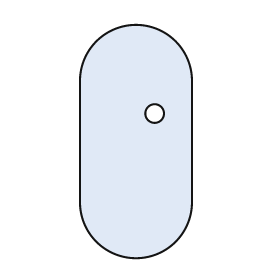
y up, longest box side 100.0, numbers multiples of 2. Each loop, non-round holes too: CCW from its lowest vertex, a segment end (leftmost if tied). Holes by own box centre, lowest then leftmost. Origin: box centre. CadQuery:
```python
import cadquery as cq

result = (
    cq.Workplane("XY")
    .moveTo(-24.0, -26.0)
    .threePointArc((0.0, -50.0), (24.0, -26.0))
    .lineTo(24.0, 26.0)
    .threePointArc((0.0, 50.0), (-24.0, 26.0))
    .close()
    .moveTo(8.0, 12.0)
    .circle(4.0)
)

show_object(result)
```